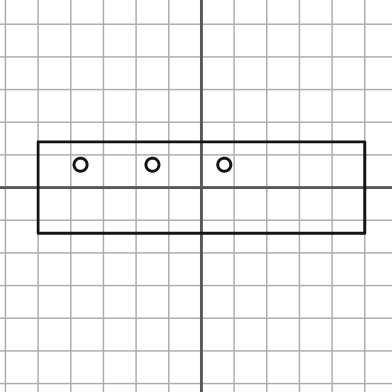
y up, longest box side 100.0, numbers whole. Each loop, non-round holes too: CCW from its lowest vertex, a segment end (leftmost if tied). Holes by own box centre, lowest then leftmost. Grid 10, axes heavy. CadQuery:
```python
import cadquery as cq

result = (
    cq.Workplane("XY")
    .moveTo(-50.0, -14.0)
    .lineTo(50.0, -14.0)
    .lineTo(50.0, 14.0)
    .lineTo(-50.0, 14.0)
    .close()
    .moveTo(-37.0, 7.0)
    .circle(2.0)
    .moveTo(-15.0, 7.0)
    .circle(2.0)
    .moveTo(7.0, 7.0)
    .circle(2.0)
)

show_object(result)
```